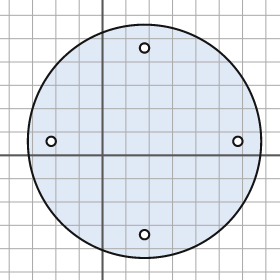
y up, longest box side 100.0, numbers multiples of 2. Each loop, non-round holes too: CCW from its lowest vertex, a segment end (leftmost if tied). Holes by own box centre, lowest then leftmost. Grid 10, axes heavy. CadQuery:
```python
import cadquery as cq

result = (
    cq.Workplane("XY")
    .moveTo(18.0, 6.0)
    .circle(50.0)
    .moveTo(18.0, -34.0)
    .circle(2.0)
    .moveTo(-22.0, 6.0)
    .circle(2.0)
    .moveTo(58.0, 6.0)
    .circle(2.0)
    .moveTo(18.0, 46.0)
    .circle(2.0)
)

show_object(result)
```